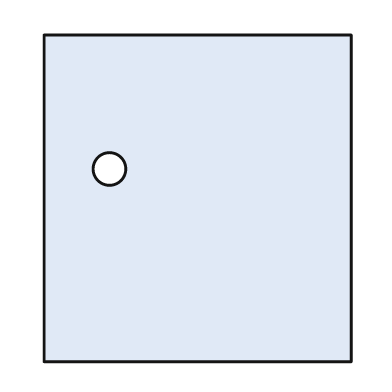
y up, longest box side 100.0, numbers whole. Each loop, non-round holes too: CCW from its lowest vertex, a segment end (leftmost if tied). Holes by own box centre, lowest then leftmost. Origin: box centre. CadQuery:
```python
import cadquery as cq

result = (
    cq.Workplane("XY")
    .moveTo(-47.0, -50.0)
    .lineTo(47.0, -50.0)
    .lineTo(47.0, 50.0)
    .lineTo(-47.0, 50.0)
    .close()
    .moveTo(-27.0, 9.0)
    .circle(5.0)
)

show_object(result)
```